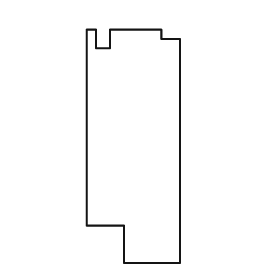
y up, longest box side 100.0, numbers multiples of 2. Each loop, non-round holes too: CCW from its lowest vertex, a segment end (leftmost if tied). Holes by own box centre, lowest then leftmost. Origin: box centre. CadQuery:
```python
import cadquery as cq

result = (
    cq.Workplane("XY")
    .moveTo(-4.0, -50.0)
    .lineTo(20.0, -50.0)
    .lineTo(20.0, 46.0)
    .lineTo(12.0, 46.0)
    .lineTo(12.0, 50.0)
    .lineTo(-10.0, 50.0)
    .lineTo(-10.0, 42.0)
    .lineTo(-16.0, 42.0)
    .lineTo(-16.0, 50.0)
    .lineTo(-20.0, 50.0)
    .lineTo(-20.0, -34.0)
    .lineTo(-4.0, -34.0)
    .close()
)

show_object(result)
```